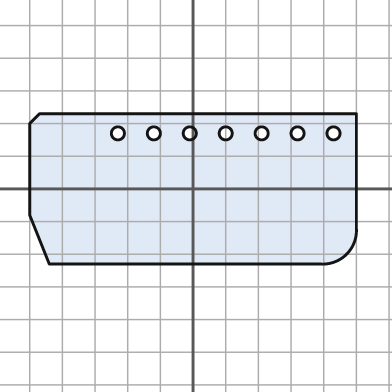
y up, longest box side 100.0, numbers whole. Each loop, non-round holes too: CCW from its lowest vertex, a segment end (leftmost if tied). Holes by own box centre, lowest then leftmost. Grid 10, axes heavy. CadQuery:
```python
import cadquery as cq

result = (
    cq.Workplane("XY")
    .moveTo(-44.0, -23.0)
    .lineTo(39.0, -23.0)
    .threePointArc((47.0, -20.0), (50.0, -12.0))
    .lineTo(50.0, 23.0)
    .lineTo(-47.0, 23.0)
    .lineTo(-50.0, 20.0)
    .lineTo(-50.0, -8.0)
    .close()
    .moveTo(-23.0, 17.0)
    .circle(2.0)
    .moveTo(-12.0, 17.0)
    .circle(2.0)
    .moveTo(-1.0, 17.0)
    .circle(2.0)
    .moveTo(10.0, 17.0)
    .circle(2.0)
    .moveTo(21.0, 17.0)
    .circle(2.0)
    .moveTo(32.0, 17.0)
    .circle(2.0)
    .moveTo(43.0, 17.0)
    .circle(2.0)
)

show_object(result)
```